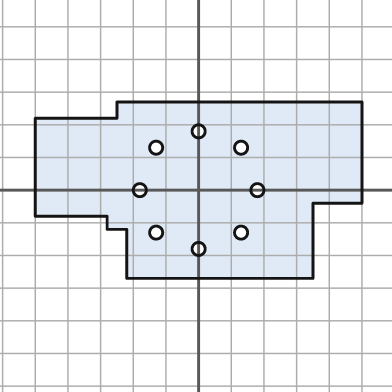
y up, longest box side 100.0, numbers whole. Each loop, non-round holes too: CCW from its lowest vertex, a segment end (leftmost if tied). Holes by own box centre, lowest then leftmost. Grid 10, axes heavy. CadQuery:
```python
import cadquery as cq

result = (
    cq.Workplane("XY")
    .moveTo(-22.0, -27.0)
    .lineTo(35.0, -27.0)
    .lineTo(35.0, -4.0)
    .lineTo(50.0, -4.0)
    .lineTo(50.0, 27.0)
    .lineTo(-25.0, 27.0)
    .lineTo(-25.0, 22.0)
    .lineTo(-50.0, 22.0)
    .lineTo(-50.0, -8.0)
    .lineTo(-28.0, -8.0)
    .lineTo(-28.0, -12.0)
    .lineTo(-22.0, -12.0)
    .close()
    .moveTo(0.0, -18.0)
    .circle(2.0)
    .moveTo(-13.0, -13.0)
    .circle(2.0)
    .moveTo(13.0, -13.0)
    .circle(2.0)
    .moveTo(-18.0, 0.0)
    .circle(2.0)
    .moveTo(18.0, 0.0)
    .circle(2.0)
    .moveTo(-13.0, 13.0)
    .circle(2.0)
    .moveTo(13.0, 13.0)
    .circle(2.0)
    .moveTo(0.0, 18.0)
    .circle(2.0)
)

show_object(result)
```